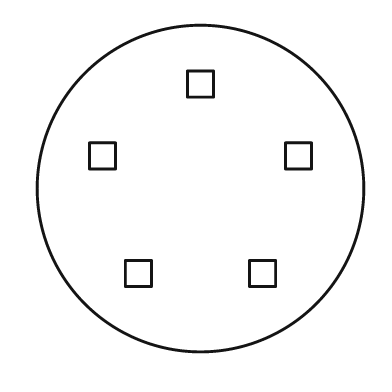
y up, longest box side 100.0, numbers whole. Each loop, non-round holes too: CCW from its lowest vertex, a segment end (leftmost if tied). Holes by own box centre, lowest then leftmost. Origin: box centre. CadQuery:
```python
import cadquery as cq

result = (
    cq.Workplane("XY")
    .moveTo(0.0, 0.0)
    .circle(50.0)
    .moveTo(-23.0, -30.0)
    .lineTo(-15.0, -30.0)
    .lineTo(-15.0, -22.0)
    .lineTo(-23.0, -22.0)
    .close()
    .moveTo(15.0, -30.0)
    .lineTo(23.0, -30.0)
    .lineTo(23.0, -22.0)
    .lineTo(15.0, -22.0)
    .close()
    .moveTo(-34.0, 6.0)
    .lineTo(-26.0, 6.0)
    .lineTo(-26.0, 14.0)
    .lineTo(-34.0, 14.0)
    .close()
    .moveTo(26.0, 6.0)
    .lineTo(34.0, 6.0)
    .lineTo(34.0, 14.0)
    .lineTo(26.0, 14.0)
    .close()
    .moveTo(-4.0, 28.0)
    .lineTo(4.0, 28.0)
    .lineTo(4.0, 36.0)
    .lineTo(-4.0, 36.0)
    .close()
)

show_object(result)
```